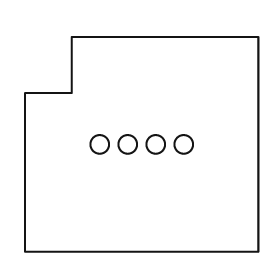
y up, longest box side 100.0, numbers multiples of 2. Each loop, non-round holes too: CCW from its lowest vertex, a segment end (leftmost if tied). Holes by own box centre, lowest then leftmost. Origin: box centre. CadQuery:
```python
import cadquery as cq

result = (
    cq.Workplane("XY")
    .moveTo(-50.0, -46.0)
    .lineTo(50.0, -46.0)
    .lineTo(50.0, 46.0)
    .lineTo(-30.0, 46.0)
    .lineTo(-30.0, 22.0)
    .lineTo(-50.0, 22.0)
    .close()
    .moveTo(-18.0, 0.0)
    .circle(4.0)
    .moveTo(-6.0, 0.0)
    .circle(4.0)
    .moveTo(6.0, 0.0)
    .circle(4.0)
    .moveTo(18.0, 0.0)
    .circle(4.0)
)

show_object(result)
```